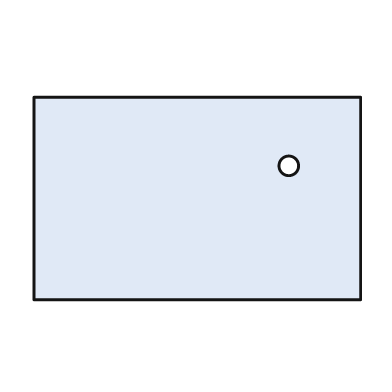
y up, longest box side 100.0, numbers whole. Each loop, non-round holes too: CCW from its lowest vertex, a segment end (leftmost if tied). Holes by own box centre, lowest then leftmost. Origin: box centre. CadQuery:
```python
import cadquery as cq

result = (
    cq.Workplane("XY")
    .moveTo(-50.0, -31.0)
    .lineTo(50.0, -31.0)
    .lineTo(50.0, 31.0)
    .lineTo(-50.0, 31.0)
    .close()
    .moveTo(28.0, 10.0)
    .circle(3.0)
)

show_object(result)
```